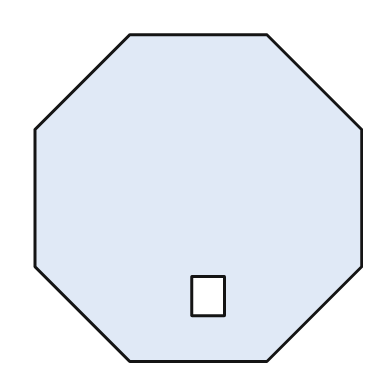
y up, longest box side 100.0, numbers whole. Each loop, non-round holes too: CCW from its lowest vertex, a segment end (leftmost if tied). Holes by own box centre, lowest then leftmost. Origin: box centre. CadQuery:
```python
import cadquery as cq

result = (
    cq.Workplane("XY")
    .moveTo(-21.0, -50.0)
    .lineTo(21.0, -50.0)
    .lineTo(50.0, -21.0)
    .lineTo(50.0, 21.0)
    .lineTo(21.0, 50.0)
    .lineTo(-21.0, 50.0)
    .lineTo(-50.0, 21.0)
    .lineTo(-50.0, -21.0)
    .close()
    .moveTo(-2.0, -36.0)
    .lineTo(8.0, -36.0)
    .lineTo(8.0, -24.0)
    .lineTo(-2.0, -24.0)
    .close()
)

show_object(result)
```